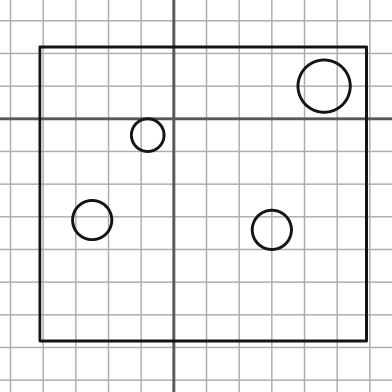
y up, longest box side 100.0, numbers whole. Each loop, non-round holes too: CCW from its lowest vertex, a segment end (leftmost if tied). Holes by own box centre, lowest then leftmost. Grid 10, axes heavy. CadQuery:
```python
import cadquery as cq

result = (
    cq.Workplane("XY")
    .moveTo(-41.0, -68.0)
    .lineTo(59.0, -68.0)
    .lineTo(59.0, 22.0)
    .lineTo(-41.0, 22.0)
    .close()
    .moveTo(30.0, -34.0)
    .circle(6.0)
    .moveTo(-25.0, -31.0)
    .circle(6.0)
    .moveTo(-8.0, -5.0)
    .circle(5.0)
    .moveTo(46.0, 10.0)
    .circle(8.0)
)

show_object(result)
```